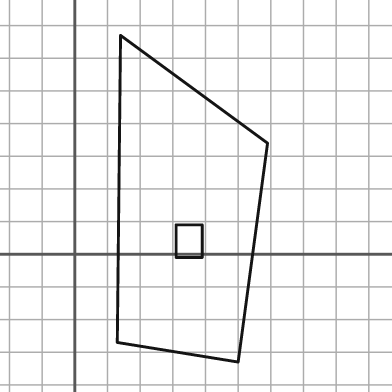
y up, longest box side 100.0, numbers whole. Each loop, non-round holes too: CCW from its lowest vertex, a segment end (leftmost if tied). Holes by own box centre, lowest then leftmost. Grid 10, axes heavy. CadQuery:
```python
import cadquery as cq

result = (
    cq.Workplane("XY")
    .moveTo(50.0, -33.0)
    .lineTo(59.0, 34.0)
    .lineTo(14.0, 67.0)
    .lineTo(13.0, -27.0)
    .close()
    .moveTo(31.0, -1.0)
    .lineTo(39.0, -1.0)
    .lineTo(39.0, 9.0)
    .lineTo(31.0, 9.0)
    .close()
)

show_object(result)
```